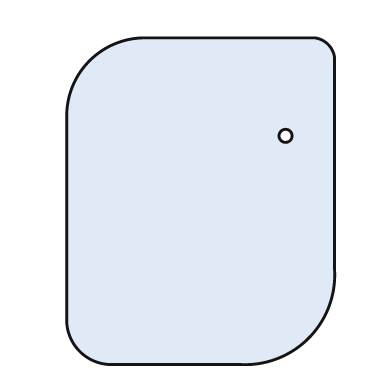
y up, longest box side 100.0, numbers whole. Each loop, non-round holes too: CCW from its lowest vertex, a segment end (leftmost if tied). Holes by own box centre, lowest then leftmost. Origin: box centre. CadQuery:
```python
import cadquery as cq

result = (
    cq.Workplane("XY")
    .moveTo(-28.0, -50.0)
    .lineTo(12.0, -50.0)
    .threePointArc((33.0, -42.0), (41.0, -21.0))
    .lineTo(41.0, 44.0)
    .threePointArc((39.0, 48.0), (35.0, 50.0))
    .lineTo(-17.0, 50.0)
    .threePointArc((-34.0, 43.0), (-41.0, 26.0))
    .lineTo(-41.0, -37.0)
    .threePointArc((-37.0, -46.0), (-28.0, -50.0))
    .close()
    .moveTo(26.0, 20.0)
    .circle(2.0)
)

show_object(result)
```